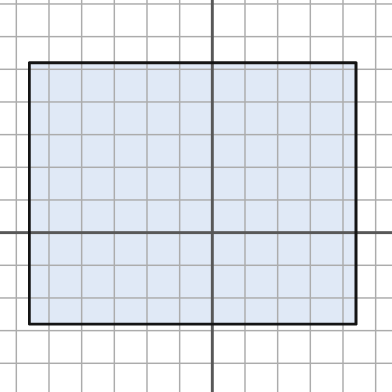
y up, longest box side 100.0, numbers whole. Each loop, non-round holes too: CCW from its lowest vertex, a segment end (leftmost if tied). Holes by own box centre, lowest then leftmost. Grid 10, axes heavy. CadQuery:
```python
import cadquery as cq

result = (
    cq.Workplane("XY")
    .moveTo(-56.0, -28.0)
    .lineTo(44.0, -28.0)
    .lineTo(44.0, 52.0)
    .lineTo(-56.0, 52.0)
    .close()
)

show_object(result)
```